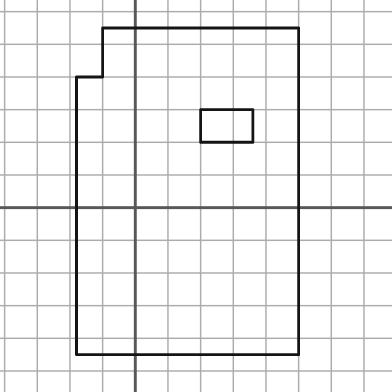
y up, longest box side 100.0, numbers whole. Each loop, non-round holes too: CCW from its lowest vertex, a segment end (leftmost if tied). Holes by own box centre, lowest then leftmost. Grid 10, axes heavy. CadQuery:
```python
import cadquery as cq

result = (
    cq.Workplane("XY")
    .moveTo(-18.0, -45.0)
    .lineTo(50.0, -45.0)
    .lineTo(50.0, 55.0)
    .lineTo(-10.0, 55.0)
    .lineTo(-10.0, 40.0)
    .lineTo(-18.0, 40.0)
    .close()
    .moveTo(20.0, 20.0)
    .lineTo(36.0, 20.0)
    .lineTo(36.0, 30.0)
    .lineTo(20.0, 30.0)
    .close()
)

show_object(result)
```